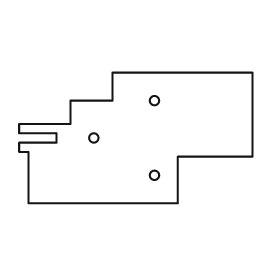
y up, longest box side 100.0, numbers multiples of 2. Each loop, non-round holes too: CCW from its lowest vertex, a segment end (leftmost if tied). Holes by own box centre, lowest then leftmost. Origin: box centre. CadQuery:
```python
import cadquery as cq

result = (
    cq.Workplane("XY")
    .moveTo(-46.0, -28.0)
    .lineTo(18.0, -28.0)
    .lineTo(18.0, -8.0)
    .lineTo(50.0, -8.0)
    .lineTo(50.0, 28.0)
    .lineTo(-10.0, 28.0)
    .lineTo(-10.0, 16.0)
    .lineTo(-28.0, 16.0)
    .lineTo(-28.0, 6.0)
    .lineTo(-50.0, 6.0)
    .lineTo(-50.0, 2.0)
    .lineTo(-34.0, 2.0)
    .lineTo(-34.0, -2.0)
    .lineTo(-50.0, -2.0)
    .lineTo(-50.0, -6.0)
    .lineTo(-46.0, -6.0)
    .close()
    .moveTo(8.0, -16.0)
    .circle(2.0)
    .moveTo(-18.0, 0.0)
    .circle(2.0)
    .moveTo(8.0, 16.0)
    .circle(2.0)
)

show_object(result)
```